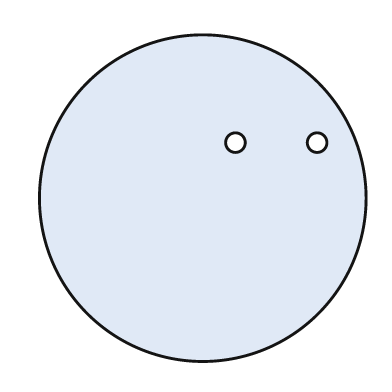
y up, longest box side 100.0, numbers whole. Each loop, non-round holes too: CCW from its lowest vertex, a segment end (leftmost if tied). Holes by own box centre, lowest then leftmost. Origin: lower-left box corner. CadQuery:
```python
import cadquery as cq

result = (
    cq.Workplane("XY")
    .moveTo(50.0, 50.0)
    .circle(50.0)
    .moveTo(60.0, 67.0)
    .circle(3.0)
    .moveTo(85.0, 67.0)
    .circle(3.0)
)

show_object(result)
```